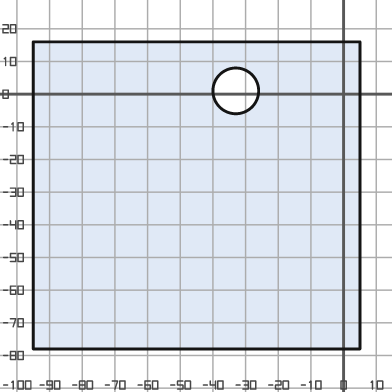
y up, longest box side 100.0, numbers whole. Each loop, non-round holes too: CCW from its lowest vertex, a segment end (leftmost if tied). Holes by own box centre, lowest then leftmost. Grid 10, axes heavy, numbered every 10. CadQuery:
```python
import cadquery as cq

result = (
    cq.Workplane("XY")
    .moveTo(-95.0, -78.0)
    .lineTo(5.0, -78.0)
    .lineTo(5.0, 16.0)
    .lineTo(-95.0, 16.0)
    .close()
    .moveTo(-33.0, 1.0)
    .circle(7.0)
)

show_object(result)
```